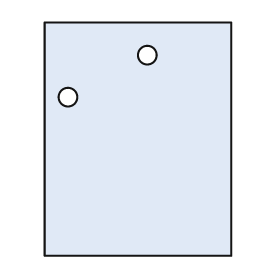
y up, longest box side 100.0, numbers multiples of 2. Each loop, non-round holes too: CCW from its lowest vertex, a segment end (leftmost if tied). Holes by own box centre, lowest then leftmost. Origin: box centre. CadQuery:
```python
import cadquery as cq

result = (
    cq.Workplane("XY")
    .moveTo(-40.0, -50.0)
    .lineTo(40.0, -50.0)
    .lineTo(40.0, 50.0)
    .lineTo(-40.0, 50.0)
    .close()
    .moveTo(-30.0, 18.0)
    .circle(4.0)
    .moveTo(4.0, 36.0)
    .circle(4.0)
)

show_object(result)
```